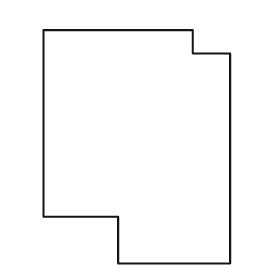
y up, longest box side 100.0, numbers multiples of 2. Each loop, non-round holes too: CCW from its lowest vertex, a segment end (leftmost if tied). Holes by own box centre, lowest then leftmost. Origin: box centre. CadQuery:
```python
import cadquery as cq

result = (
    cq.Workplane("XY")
    .moveTo(-8.0, -50.0)
    .lineTo(40.0, -50.0)
    .lineTo(40.0, 40.0)
    .lineTo(24.0, 40.0)
    .lineTo(24.0, 50.0)
    .lineTo(-40.0, 50.0)
    .lineTo(-40.0, -30.0)
    .lineTo(-8.0, -30.0)
    .close()
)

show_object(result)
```